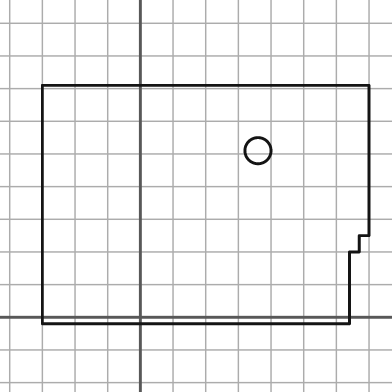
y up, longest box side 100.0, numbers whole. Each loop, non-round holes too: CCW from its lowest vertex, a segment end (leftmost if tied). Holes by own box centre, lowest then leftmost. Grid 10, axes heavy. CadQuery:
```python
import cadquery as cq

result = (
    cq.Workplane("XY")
    .moveTo(-30.0, -2.0)
    .lineTo(64.0, -2.0)
    .lineTo(64.0, 20.0)
    .lineTo(67.0, 20.0)
    .lineTo(67.0, 25.0)
    .lineTo(70.0, 25.0)
    .lineTo(70.0, 71.0)
    .lineTo(-30.0, 71.0)
    .close()
    .moveTo(36.0, 51.0)
    .circle(4.0)
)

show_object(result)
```